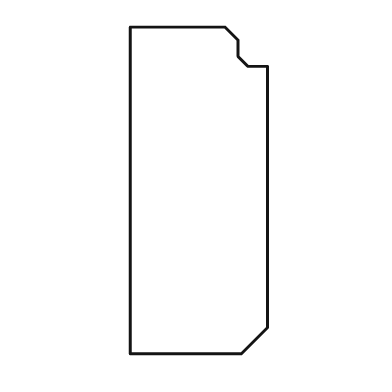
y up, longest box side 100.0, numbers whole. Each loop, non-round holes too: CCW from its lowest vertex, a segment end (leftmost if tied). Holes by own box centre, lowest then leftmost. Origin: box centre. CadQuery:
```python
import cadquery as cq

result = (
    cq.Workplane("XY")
    .moveTo(-21.0, -50.0)
    .lineTo(13.0, -50.0)
    .lineTo(21.0, -42.0)
    .lineTo(21.0, 38.0)
    .lineTo(15.0, 38.0)
    .lineTo(12.0, 41.0)
    .lineTo(12.0, 46.0)
    .lineTo(8.0, 50.0)
    .lineTo(-21.0, 50.0)
    .close()
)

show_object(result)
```